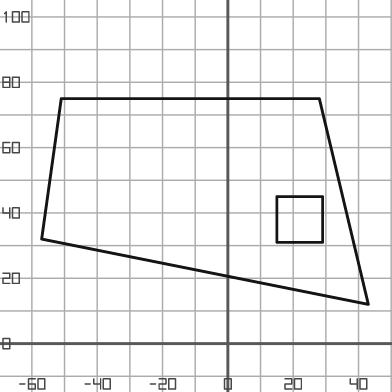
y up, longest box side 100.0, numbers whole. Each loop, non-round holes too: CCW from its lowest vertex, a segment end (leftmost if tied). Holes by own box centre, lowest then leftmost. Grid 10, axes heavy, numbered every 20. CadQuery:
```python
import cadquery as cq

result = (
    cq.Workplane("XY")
    .moveTo(43.0, 12.0)
    .lineTo(28.0, 75.0)
    .lineTo(-51.0, 75.0)
    .lineTo(-57.0, 32.0)
    .close()
    .moveTo(15.0, 31.0)
    .lineTo(29.0, 31.0)
    .lineTo(29.0, 45.0)
    .lineTo(15.0, 45.0)
    .close()
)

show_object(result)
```